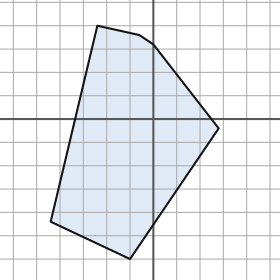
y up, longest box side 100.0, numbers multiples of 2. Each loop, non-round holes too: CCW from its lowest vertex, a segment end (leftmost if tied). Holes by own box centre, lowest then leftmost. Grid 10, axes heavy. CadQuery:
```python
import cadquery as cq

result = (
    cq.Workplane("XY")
    .moveTo(-10.0, -60.0)
    .lineTo(28.0, -4.0)
    .lineTo(0.0, 32.0)
    .lineTo(-6.0, 36.0)
    .lineTo(-24.0, 40.0)
    .lineTo(-44.0, -44.0)
    .close()
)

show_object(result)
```